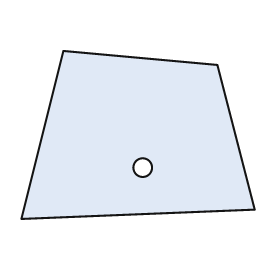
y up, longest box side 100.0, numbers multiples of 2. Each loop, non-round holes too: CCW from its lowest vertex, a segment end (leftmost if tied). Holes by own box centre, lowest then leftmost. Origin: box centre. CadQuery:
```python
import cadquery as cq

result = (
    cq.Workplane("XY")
    .moveTo(-50.0, -36.0)
    .lineTo(50.0, -32.0)
    .lineTo(34.0, 30.0)
    .lineTo(-32.0, 36.0)
    .close()
    .moveTo(2.0, -14.0)
    .circle(4.0)
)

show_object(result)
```